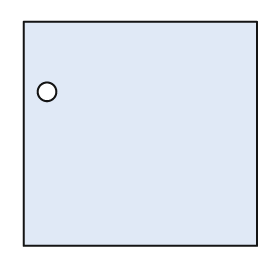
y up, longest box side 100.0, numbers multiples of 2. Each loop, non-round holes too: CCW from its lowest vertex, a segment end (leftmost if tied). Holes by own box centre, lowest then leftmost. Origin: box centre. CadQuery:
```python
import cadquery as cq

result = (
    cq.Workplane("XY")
    .moveTo(-50.0, -48.0)
    .lineTo(50.0, -48.0)
    .lineTo(50.0, 48.0)
    .lineTo(-50.0, 48.0)
    .close()
    .moveTo(-40.0, 18.0)
    .circle(4.0)
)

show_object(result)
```